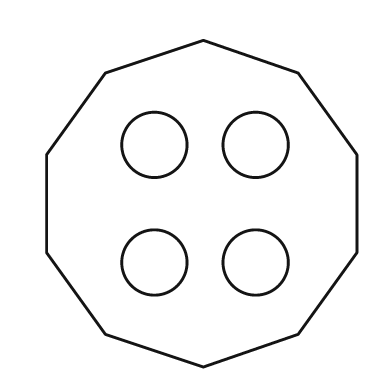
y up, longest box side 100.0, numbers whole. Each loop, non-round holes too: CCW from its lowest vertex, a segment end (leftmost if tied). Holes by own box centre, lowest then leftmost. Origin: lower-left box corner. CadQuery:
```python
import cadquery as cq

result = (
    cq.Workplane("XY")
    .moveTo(48.0, 0.0)
    .lineTo(77.0, 10.0)
    .lineTo(95.0, 35.0)
    .lineTo(95.0, 65.0)
    .lineTo(77.0, 90.0)
    .lineTo(48.0, 100.0)
    .lineTo(18.0, 90.0)
    .lineTo(0.0, 65.0)
    .lineTo(0.0, 35.0)
    .lineTo(18.0, 10.0)
    .close()
    .moveTo(33.0, 32.0)
    .circle(10.0)
    .moveTo(64.0, 32.0)
    .circle(10.0)
    .moveTo(33.0, 68.0)
    .circle(10.0)
    .moveTo(64.0, 68.0)
    .circle(10.0)
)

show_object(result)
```